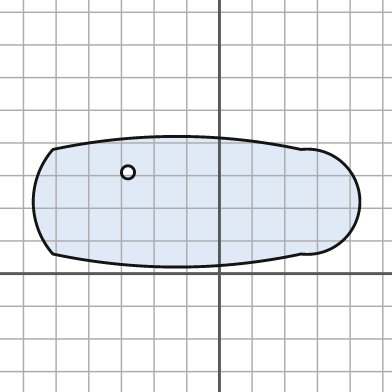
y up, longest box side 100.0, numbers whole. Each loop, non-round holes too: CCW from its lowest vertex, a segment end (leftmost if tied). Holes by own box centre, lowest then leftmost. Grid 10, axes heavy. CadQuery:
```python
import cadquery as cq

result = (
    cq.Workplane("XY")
    .moveTo(-51.0, 6.0)
    .threePointArc((-13.0, 2.0), (25.0, 6.0))
    .threePointArc((43.0, 22.0), (25.0, 38.0))
    .threePointArc((-13.0, 42.0), (-51.0, 38.0))
    .threePointArc((-57.0, 22.0), (-51.0, 6.0))
    .close()
    .moveTo(-28.0, 31.0)
    .circle(2.0)
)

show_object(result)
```